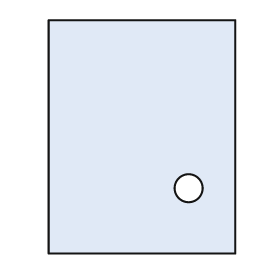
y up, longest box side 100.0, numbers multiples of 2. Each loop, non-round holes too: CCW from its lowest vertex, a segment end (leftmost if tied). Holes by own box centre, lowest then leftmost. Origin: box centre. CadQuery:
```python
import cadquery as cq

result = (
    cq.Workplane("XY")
    .moveTo(-40.0, -50.0)
    .lineTo(40.0, -50.0)
    .lineTo(40.0, 50.0)
    .lineTo(-40.0, 50.0)
    .close()
    .moveTo(20.0, -22.0)
    .circle(6.0)
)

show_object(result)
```